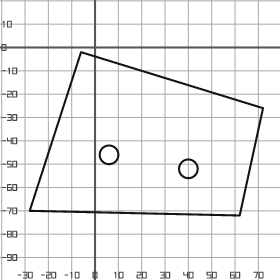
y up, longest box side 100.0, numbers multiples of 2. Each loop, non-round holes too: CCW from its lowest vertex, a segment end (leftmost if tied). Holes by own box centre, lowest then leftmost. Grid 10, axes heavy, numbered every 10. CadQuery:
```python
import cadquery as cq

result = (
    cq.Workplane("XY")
    .moveTo(62.0, -72.0)
    .lineTo(72.0, -26.0)
    .lineTo(-6.0, -2.0)
    .lineTo(-28.0, -70.0)
    .close()
    .moveTo(40.0, -52.0)
    .circle(4.0)
    .moveTo(6.0, -46.0)
    .circle(4.0)
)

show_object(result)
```